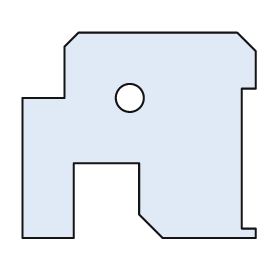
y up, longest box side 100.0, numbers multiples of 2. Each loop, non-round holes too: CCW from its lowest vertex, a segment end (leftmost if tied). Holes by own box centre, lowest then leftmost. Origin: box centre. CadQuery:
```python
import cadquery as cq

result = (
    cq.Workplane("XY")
    .moveTo(-50.0, -44.0)
    .lineTo(-28.0, -44.0)
    .lineTo(-28.0, -12.0)
    .lineTo(0.0, -12.0)
    .lineTo(0.0, -34.0)
    .lineTo(10.0, -44.0)
    .lineTo(50.0, -44.0)
    .lineTo(50.0, -40.0)
    .lineTo(44.0, -40.0)
    .lineTo(44.0, 20.0)
    .lineTo(50.0, 20.0)
    .lineTo(50.0, 36.0)
    .lineTo(42.0, 44.0)
    .lineTo(-26.0, 44.0)
    .lineTo(-32.0, 38.0)
    .lineTo(-32.0, 16.0)
    .lineTo(-50.0, 16.0)
    .close()
    .moveTo(-4.0, 16.0)
    .circle(6.0)
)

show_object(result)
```